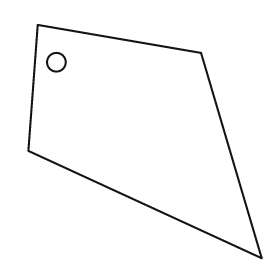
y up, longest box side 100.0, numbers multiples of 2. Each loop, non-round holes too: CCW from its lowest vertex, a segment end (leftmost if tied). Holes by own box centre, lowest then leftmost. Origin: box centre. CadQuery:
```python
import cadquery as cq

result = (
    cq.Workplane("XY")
    .moveTo(50.0, -50.0)
    .lineTo(24.0, 38.0)
    .lineTo(-46.0, 50.0)
    .lineTo(-50.0, -4.0)
    .close()
    .moveTo(-38.0, 34.0)
    .circle(4.0)
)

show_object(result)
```